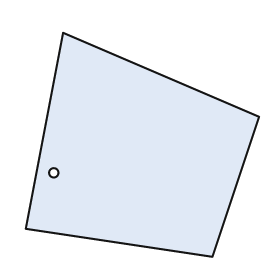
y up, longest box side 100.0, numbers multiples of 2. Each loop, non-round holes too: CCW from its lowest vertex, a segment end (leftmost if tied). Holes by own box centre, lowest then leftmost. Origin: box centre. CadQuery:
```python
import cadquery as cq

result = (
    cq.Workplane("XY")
    .moveTo(30.0, -48.0)
    .lineTo(50.0, 12.0)
    .lineTo(-34.0, 48.0)
    .lineTo(-50.0, -36.0)
    .close()
    .moveTo(-38.0, -12.0)
    .circle(2.0)
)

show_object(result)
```